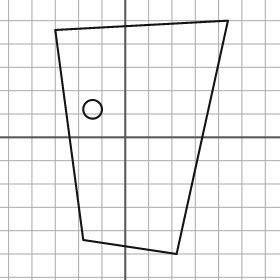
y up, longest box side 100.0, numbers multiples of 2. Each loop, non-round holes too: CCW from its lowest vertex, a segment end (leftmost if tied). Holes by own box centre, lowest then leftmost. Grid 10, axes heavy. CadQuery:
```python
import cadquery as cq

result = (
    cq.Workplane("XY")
    .moveTo(22.0, -50.0)
    .lineTo(44.0, 50.0)
    .lineTo(-30.0, 46.0)
    .lineTo(-18.0, -44.0)
    .close()
    .moveTo(-14.0, 12.0)
    .circle(4.0)
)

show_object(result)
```